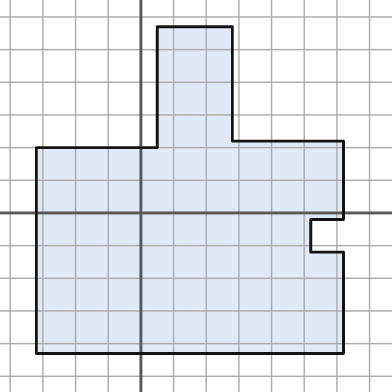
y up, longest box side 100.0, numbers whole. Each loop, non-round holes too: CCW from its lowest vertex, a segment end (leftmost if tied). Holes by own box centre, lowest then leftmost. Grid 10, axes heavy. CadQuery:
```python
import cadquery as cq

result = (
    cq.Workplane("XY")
    .moveTo(-32.0, -43.0)
    .lineTo(62.0, -43.0)
    .lineTo(62.0, -12.0)
    .lineTo(52.0, -12.0)
    .lineTo(52.0, -2.0)
    .lineTo(62.0, -2.0)
    .lineTo(62.0, 22.0)
    .lineTo(28.0, 22.0)
    .lineTo(28.0, 57.0)
    .lineTo(5.0, 57.0)
    .lineTo(5.0, 20.0)
    .lineTo(-32.0, 20.0)
    .close()
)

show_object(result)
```